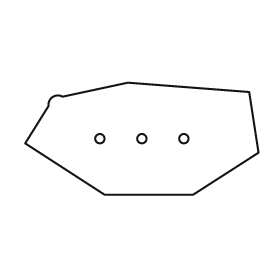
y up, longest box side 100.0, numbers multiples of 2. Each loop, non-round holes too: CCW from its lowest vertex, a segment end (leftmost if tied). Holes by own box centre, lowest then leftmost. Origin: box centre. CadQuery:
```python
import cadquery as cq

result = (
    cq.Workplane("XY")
    .moveTo(-16.0, -24.0)
    .lineTo(22.0, -24.0)
    .lineTo(50.0, -6.0)
    .lineTo(46.0, 20.0)
    .lineTo(-6.0, 24.0)
    .lineTo(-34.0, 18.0)
    .threePointArc((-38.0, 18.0), (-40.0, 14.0))
    .lineTo(-50.0, -2.0)
    .close()
    .moveTo(-18.0, 0.0)
    .circle(2.0)
    .moveTo(0.0, 0.0)
    .circle(2.0)
    .moveTo(18.0, 0.0)
    .circle(2.0)
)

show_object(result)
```